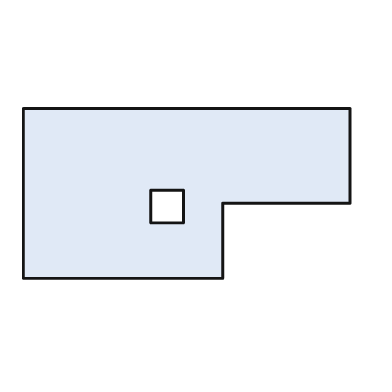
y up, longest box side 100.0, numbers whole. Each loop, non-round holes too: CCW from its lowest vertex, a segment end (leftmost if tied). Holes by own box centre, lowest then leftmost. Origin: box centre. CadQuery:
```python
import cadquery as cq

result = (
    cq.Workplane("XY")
    .moveTo(-50.0, -26.0)
    .lineTo(11.0, -26.0)
    .lineTo(11.0, -3.0)
    .lineTo(50.0, -3.0)
    .lineTo(50.0, 26.0)
    .lineTo(-50.0, 26.0)
    .close()
    .moveTo(-11.0, -9.0)
    .lineTo(-1.0, -9.0)
    .lineTo(-1.0, 1.0)
    .lineTo(-11.0, 1.0)
    .close()
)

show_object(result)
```